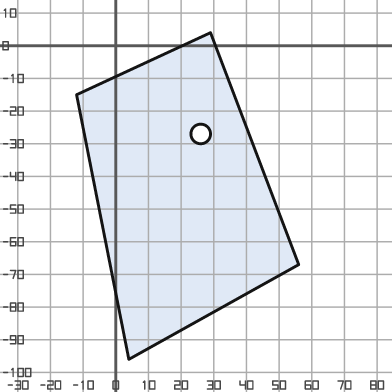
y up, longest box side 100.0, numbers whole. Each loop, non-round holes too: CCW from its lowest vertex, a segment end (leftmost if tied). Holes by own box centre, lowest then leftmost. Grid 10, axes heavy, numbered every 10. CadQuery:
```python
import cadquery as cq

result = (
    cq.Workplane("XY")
    .moveTo(4.0, -96.0)
    .lineTo(56.0, -67.0)
    .lineTo(29.0, 4.0)
    .lineTo(-12.0, -15.0)
    .close()
    .moveTo(26.0, -27.0)
    .circle(3.0)
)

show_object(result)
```